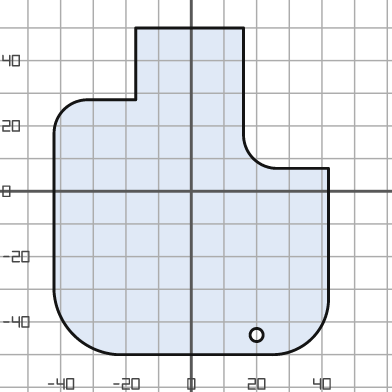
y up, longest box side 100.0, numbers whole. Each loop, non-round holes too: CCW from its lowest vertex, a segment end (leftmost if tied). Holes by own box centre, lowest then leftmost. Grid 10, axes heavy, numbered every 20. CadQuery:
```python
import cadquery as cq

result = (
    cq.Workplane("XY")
    .moveTo(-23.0, -50.0)
    .lineTo(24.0, -50.0)
    .threePointArc((37.0, -45.0), (42.0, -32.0))
    .lineTo(42.0, 7.0)
    .lineTo(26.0, 7.0)
    .threePointArc((19.0, 10.0), (16.0, 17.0))
    .lineTo(16.0, 50.0)
    .lineTo(-17.0, 50.0)
    .lineTo(-17.0, 28.0)
    .lineTo(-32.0, 28.0)
    .threePointArc((-39.0, 25.0), (-42.0, 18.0))
    .lineTo(-42.0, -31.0)
    .threePointArc((-36.0, -44.0), (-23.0, -50.0))
    .close()
    .moveTo(20.0, -44.0)
    .circle(2.0)
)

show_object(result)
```